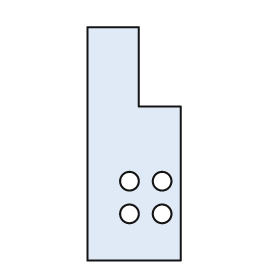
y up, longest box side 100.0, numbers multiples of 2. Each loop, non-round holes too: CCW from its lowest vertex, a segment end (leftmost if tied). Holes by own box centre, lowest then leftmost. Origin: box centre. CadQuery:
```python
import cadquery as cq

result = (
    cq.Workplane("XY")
    .moveTo(-20.0, -50.0)
    .lineTo(20.0, -50.0)
    .lineTo(20.0, 16.0)
    .lineTo(2.0, 16.0)
    .lineTo(2.0, 50.0)
    .lineTo(-20.0, 50.0)
    .close()
    .moveTo(-2.0, -30.0)
    .circle(4.0)
    .moveTo(12.0, -30.0)
    .circle(4.0)
    .moveTo(-2.0, -16.0)
    .circle(4.0)
    .moveTo(12.0, -16.0)
    .circle(4.0)
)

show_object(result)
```